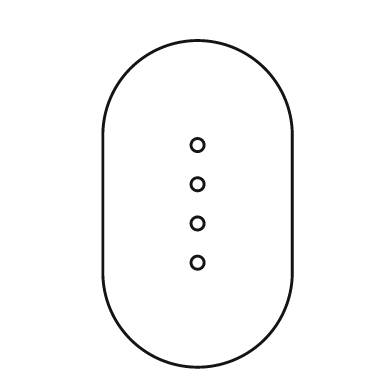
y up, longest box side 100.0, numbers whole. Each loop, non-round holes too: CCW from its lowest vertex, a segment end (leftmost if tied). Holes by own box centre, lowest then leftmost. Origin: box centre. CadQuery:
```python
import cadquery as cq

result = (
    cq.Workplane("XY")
    .moveTo(-29.0, -21.0)
    .threePointArc((0.0, -50.0), (29.0, -21.0))
    .lineTo(29.0, 21.0)
    .threePointArc((0.0, 50.0), (-29.0, 21.0))
    .close()
    .moveTo(0.0, -18.0)
    .circle(2.0)
    .moveTo(0.0, -6.0)
    .circle(2.0)
    .moveTo(0.0, 6.0)
    .circle(2.0)
    .moveTo(0.0, 18.0)
    .circle(2.0)
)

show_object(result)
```